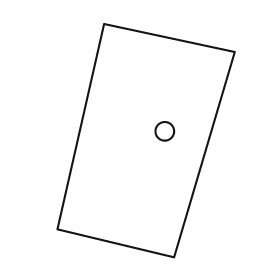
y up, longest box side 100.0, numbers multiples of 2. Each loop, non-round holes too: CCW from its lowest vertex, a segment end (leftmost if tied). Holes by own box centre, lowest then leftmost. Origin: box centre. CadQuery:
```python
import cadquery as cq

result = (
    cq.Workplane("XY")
    .moveTo(12.0, -50.0)
    .lineTo(38.0, 38.0)
    .lineTo(-18.0, 50.0)
    .lineTo(-38.0, -38.0)
    .close()
    .moveTo(8.0, 4.0)
    .circle(4.0)
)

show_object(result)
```